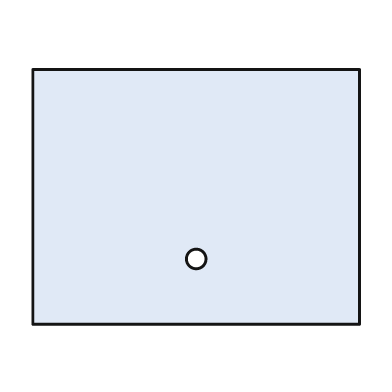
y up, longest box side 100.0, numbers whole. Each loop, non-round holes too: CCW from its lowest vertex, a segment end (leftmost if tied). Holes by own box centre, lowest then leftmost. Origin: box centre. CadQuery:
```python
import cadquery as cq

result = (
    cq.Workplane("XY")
    .moveTo(-50.0, -39.0)
    .lineTo(50.0, -39.0)
    .lineTo(50.0, 39.0)
    .lineTo(-50.0, 39.0)
    .close()
    .moveTo(0.0, -19.0)
    .circle(3.0)
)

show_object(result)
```